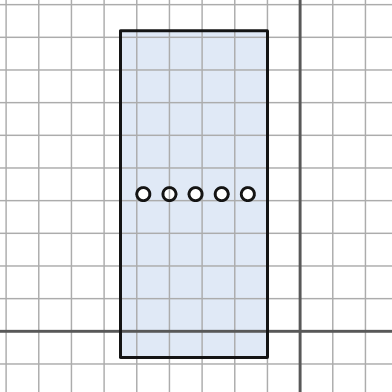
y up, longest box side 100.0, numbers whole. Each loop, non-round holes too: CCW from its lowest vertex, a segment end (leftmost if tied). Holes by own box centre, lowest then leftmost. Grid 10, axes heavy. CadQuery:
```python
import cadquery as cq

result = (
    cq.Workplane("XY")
    .moveTo(-55.0, -8.0)
    .lineTo(-10.0, -8.0)
    .lineTo(-10.0, 92.0)
    .lineTo(-55.0, 92.0)
    .close()
    .moveTo(-48.0, 42.0)
    .circle(2.0)
    .moveTo(-40.0, 42.0)
    .circle(2.0)
    .moveTo(-32.0, 42.0)
    .circle(2.0)
    .moveTo(-24.0, 42.0)
    .circle(2.0)
    .moveTo(-16.0, 42.0)
    .circle(2.0)
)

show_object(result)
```